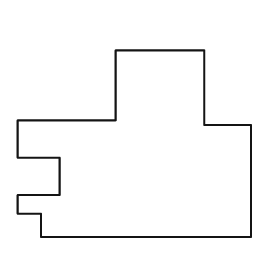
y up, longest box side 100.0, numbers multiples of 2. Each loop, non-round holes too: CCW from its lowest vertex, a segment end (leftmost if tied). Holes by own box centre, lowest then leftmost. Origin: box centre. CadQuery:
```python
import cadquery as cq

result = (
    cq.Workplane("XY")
    .moveTo(-40.0, -40.0)
    .lineTo(50.0, -40.0)
    .lineTo(50.0, 8.0)
    .lineTo(30.0, 8.0)
    .lineTo(30.0, 40.0)
    .lineTo(-8.0, 40.0)
    .lineTo(-8.0, 10.0)
    .lineTo(-50.0, 10.0)
    .lineTo(-50.0, -6.0)
    .lineTo(-32.0, -6.0)
    .lineTo(-32.0, -22.0)
    .lineTo(-50.0, -22.0)
    .lineTo(-50.0, -30.0)
    .lineTo(-40.0, -30.0)
    .close()
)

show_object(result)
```